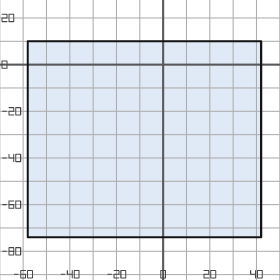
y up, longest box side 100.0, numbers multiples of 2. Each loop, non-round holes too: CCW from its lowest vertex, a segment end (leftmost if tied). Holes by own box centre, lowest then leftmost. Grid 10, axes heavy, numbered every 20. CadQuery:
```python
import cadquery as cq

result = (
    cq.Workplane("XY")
    .moveTo(-58.0, -74.0)
    .lineTo(42.0, -74.0)
    .lineTo(42.0, 10.0)
    .lineTo(-58.0, 10.0)
    .close()
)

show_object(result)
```